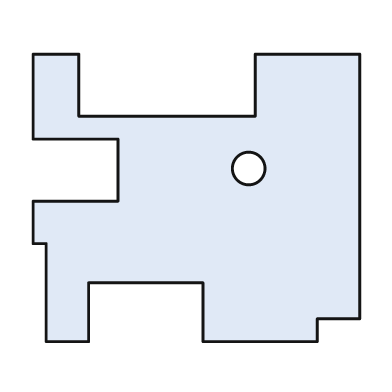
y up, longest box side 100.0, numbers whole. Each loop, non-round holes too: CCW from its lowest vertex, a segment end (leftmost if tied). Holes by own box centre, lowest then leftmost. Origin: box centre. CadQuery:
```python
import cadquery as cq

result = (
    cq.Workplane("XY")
    .moveTo(-46.0, -44.0)
    .lineTo(-33.0, -44.0)
    .lineTo(-33.0, -26.0)
    .lineTo(2.0, -26.0)
    .lineTo(2.0, -44.0)
    .lineTo(37.0, -44.0)
    .lineTo(37.0, -37.0)
    .lineTo(50.0, -37.0)
    .lineTo(50.0, 44.0)
    .lineTo(18.0, 44.0)
    .lineTo(18.0, 25.0)
    .lineTo(-36.0, 25.0)
    .lineTo(-36.0, 44.0)
    .lineTo(-50.0, 44.0)
    .lineTo(-50.0, 18.0)
    .lineTo(-24.0, 18.0)
    .lineTo(-24.0, -1.0)
    .lineTo(-50.0, -1.0)
    .lineTo(-50.0, -14.0)
    .lineTo(-46.0, -14.0)
    .close()
    .moveTo(16.0, 9.0)
    .circle(5.0)
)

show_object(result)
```